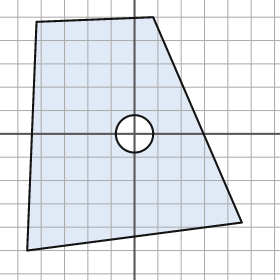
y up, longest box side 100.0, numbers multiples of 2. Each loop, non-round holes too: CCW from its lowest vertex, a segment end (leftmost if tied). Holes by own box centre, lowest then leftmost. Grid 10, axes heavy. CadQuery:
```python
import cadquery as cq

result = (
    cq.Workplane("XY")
    .moveTo(-46.0, -50.0)
    .lineTo(46.0, -38.0)
    .lineTo(8.0, 50.0)
    .lineTo(-42.0, 48.0)
    .close()
    .moveTo(0.0, 0.0)
    .circle(8.0)
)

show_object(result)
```